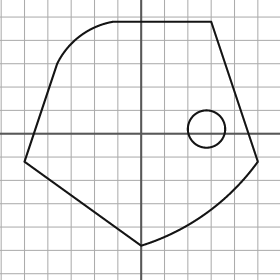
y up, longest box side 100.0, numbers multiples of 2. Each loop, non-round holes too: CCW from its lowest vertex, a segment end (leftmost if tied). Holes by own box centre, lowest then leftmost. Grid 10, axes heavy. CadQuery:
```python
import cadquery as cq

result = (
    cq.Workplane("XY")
    .moveTo(0.0, -48.0)
    .threePointArc((28.0, -34.0), (50.0, -12.0))
    .lineTo(30.0, 48.0)
    .lineTo(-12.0, 48.0)
    .threePointArc((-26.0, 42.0), (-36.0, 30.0))
    .lineTo(-50.0, -12.0)
    .close()
    .moveTo(28.0, 2.0)
    .circle(8.0)
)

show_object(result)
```